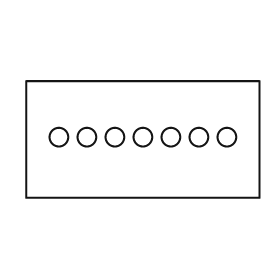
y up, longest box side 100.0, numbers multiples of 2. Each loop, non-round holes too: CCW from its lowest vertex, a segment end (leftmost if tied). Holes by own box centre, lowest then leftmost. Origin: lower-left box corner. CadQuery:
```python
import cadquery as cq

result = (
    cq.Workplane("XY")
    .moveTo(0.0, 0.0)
    .lineTo(100.0, 0.0)
    .lineTo(100.0, 50.0)
    .lineTo(0.0, 50.0)
    .close()
    .moveTo(14.0, 26.0)
    .circle(4.0)
    .moveTo(26.0, 26.0)
    .circle(4.0)
    .moveTo(38.0, 26.0)
    .circle(4.0)
    .moveTo(50.0, 26.0)
    .circle(4.0)
    .moveTo(62.0, 26.0)
    .circle(4.0)
    .moveTo(74.0, 26.0)
    .circle(4.0)
    .moveTo(86.0, 26.0)
    .circle(4.0)
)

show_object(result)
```